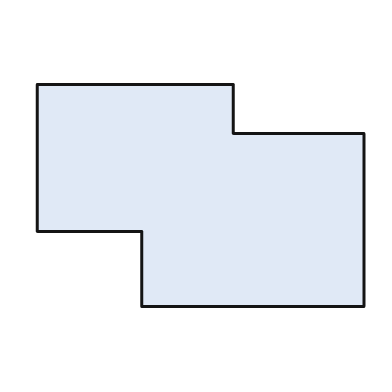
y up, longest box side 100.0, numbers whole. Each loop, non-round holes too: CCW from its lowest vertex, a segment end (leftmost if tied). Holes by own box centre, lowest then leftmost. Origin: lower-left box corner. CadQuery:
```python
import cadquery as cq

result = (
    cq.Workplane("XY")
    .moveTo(32.0, 0.0)
    .lineTo(100.0, 0.0)
    .lineTo(100.0, 53.0)
    .lineTo(60.0, 53.0)
    .lineTo(60.0, 68.0)
    .lineTo(0.0, 68.0)
    .lineTo(0.0, 23.0)
    .lineTo(32.0, 23.0)
    .close()
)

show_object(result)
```